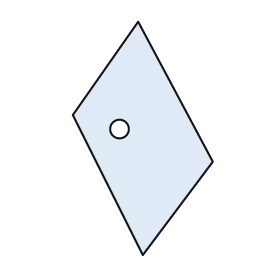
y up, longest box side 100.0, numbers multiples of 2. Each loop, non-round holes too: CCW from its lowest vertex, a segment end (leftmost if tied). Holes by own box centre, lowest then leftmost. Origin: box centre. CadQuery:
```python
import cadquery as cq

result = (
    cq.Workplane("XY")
    .moveTo(0.0, -50.0)
    .lineTo(30.0, -10.0)
    .lineTo(-2.0, 50.0)
    .lineTo(-30.0, 10.0)
    .close()
    .moveTo(-10.0, 4.0)
    .circle(4.0)
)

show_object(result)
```